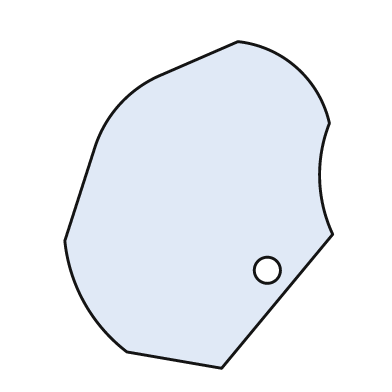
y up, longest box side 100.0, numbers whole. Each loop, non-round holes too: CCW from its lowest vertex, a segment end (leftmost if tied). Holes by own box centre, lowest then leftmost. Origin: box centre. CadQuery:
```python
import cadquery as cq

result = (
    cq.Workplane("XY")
    .moveTo(7.0, -50.0)
    .lineTo(41.0, -9.0)
    .threePointArc((37.0, 8.0), (40.0, 25.0))
    .threePointArc((30.0, 42.0), (12.0, 50.0))
    .lineTo(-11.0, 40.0)
    .threePointArc((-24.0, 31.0), (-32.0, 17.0))
    .lineTo(-41.0, -11.0)
    .threePointArc((-35.0, -30.0), (-22.0, -45.0))
    .close()
    .moveTo(21.0, -20.0)
    .circle(4.0)
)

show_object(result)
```